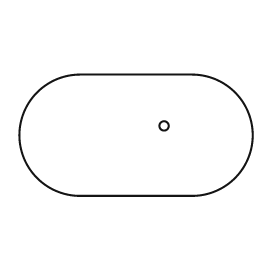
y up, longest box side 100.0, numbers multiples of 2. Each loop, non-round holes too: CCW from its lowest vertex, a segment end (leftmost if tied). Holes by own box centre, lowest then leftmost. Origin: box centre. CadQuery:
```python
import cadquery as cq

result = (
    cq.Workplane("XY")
    .moveTo(-24.0, -26.0)
    .lineTo(24.0, -26.0)
    .threePointArc((50.0, 0.0), (24.0, 26.0))
    .lineTo(-24.0, 26.0)
    .threePointArc((-50.0, 0.0), (-24.0, -26.0))
    .close()
    .moveTo(12.0, 4.0)
    .circle(2.0)
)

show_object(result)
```